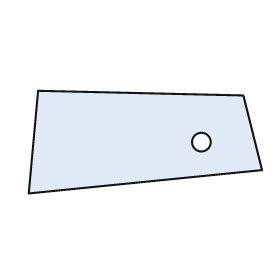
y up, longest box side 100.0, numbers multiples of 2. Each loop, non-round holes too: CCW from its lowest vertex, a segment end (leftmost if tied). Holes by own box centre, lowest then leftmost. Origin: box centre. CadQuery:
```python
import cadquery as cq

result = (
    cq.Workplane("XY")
    .moveTo(-50.0, -22.0)
    .lineTo(50.0, -12.0)
    .lineTo(42.0, 20.0)
    .lineTo(-46.0, 22.0)
    .close()
    .moveTo(24.0, 0.0)
    .circle(4.0)
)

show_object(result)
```